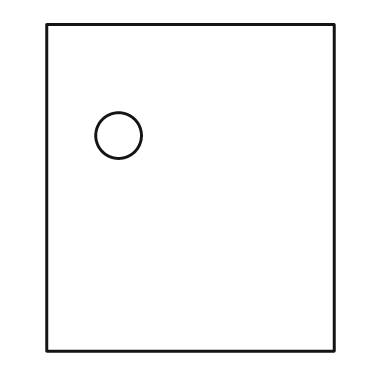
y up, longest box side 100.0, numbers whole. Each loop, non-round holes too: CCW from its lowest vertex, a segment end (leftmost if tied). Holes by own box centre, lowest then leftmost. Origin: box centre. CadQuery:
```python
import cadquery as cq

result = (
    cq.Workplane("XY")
    .moveTo(-44.0, -50.0)
    .lineTo(44.0, -50.0)
    .lineTo(44.0, 50.0)
    .lineTo(-44.0, 50.0)
    .close()
    .moveTo(-22.0, 16.0)
    .circle(7.0)
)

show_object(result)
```